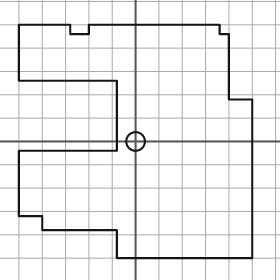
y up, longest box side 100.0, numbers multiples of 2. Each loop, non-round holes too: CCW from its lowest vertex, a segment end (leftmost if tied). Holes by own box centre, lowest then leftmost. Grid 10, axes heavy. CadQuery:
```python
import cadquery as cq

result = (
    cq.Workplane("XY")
    .moveTo(-8.0, -50.0)
    .lineTo(50.0, -50.0)
    .lineTo(50.0, 18.0)
    .lineTo(40.0, 18.0)
    .lineTo(40.0, 46.0)
    .lineTo(36.0, 46.0)
    .lineTo(36.0, 50.0)
    .lineTo(-20.0, 50.0)
    .lineTo(-20.0, 46.0)
    .lineTo(-28.0, 46.0)
    .lineTo(-28.0, 50.0)
    .lineTo(-50.0, 50.0)
    .lineTo(-50.0, 26.0)
    .lineTo(-8.0, 26.0)
    .lineTo(-8.0, -4.0)
    .lineTo(-50.0, -4.0)
    .lineTo(-50.0, -32.0)
    .lineTo(-40.0, -32.0)
    .lineTo(-40.0, -38.0)
    .lineTo(-8.0, -38.0)
    .close()
    .moveTo(0.0, 0.0)
    .circle(4.0)
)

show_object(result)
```